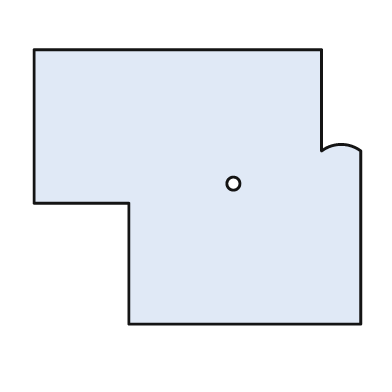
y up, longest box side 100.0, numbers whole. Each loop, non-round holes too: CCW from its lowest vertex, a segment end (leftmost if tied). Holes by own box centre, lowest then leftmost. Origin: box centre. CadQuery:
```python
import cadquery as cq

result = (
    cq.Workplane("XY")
    .moveTo(-21.0, -42.0)
    .lineTo(50.0, -42.0)
    .lineTo(50.0, 11.0)
    .threePointArc((44.0, 13.0), (38.0, 11.0))
    .lineTo(38.0, 42.0)
    .lineTo(-50.0, 42.0)
    .lineTo(-50.0, -5.0)
    .lineTo(-21.0, -5.0)
    .close()
    .moveTo(11.0, 1.0)
    .circle(2.0)
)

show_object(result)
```